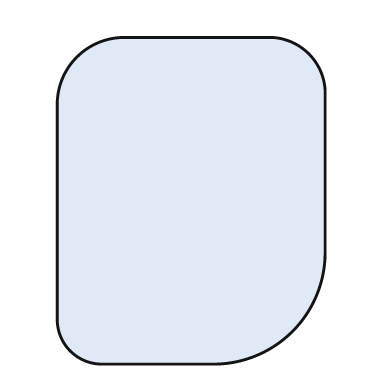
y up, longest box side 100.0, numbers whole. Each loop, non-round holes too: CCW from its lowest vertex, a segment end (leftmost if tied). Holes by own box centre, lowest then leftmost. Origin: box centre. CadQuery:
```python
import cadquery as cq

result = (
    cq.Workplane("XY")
    .moveTo(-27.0, -50.0)
    .lineTo(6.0, -50.0)
    .threePointArc((31.0, -40.0), (41.0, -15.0))
    .lineTo(41.0, 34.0)
    .threePointArc((36.0, 45.0), (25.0, 50.0))
    .lineTo(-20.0, 50.0)
    .threePointArc((-35.0, 44.0), (-41.0, 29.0))
    .lineTo(-41.0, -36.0)
    .threePointArc((-37.0, -46.0), (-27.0, -50.0))
    .close()
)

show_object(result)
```